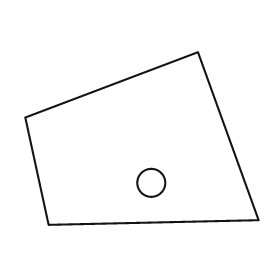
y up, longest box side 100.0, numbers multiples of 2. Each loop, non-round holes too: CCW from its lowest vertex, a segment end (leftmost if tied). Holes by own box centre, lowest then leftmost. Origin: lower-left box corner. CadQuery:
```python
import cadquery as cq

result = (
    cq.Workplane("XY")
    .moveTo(10.0, 0.0)
    .lineTo(100.0, 2.0)
    .lineTo(74.0, 74.0)
    .lineTo(0.0, 46.0)
    .close()
    .moveTo(54.0, 18.0)
    .circle(6.0)
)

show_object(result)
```